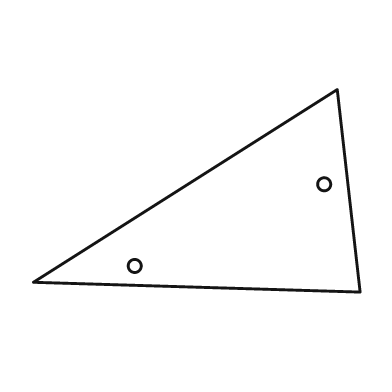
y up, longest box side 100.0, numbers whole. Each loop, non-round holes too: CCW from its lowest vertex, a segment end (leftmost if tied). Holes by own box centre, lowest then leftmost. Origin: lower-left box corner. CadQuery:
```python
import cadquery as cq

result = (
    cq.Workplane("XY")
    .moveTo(100.0, 0.0)
    .lineTo(93.0, 62.0)
    .lineTo(0.0, 3.0)
    .close()
    .moveTo(31.0, 8.0)
    .circle(2.0)
    .moveTo(89.0, 33.0)
    .circle(2.0)
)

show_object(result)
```